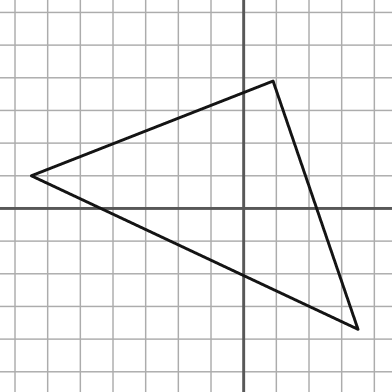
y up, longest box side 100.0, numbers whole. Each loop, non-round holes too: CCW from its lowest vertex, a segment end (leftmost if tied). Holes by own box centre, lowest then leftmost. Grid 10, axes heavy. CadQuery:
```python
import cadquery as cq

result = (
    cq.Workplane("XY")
    .moveTo(35.0, -37.0)
    .lineTo(9.0, 39.0)
    .lineTo(-65.0, 10.0)
    .close()
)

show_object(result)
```